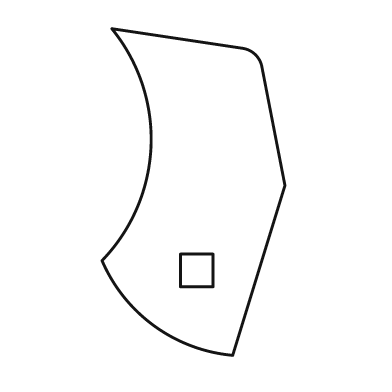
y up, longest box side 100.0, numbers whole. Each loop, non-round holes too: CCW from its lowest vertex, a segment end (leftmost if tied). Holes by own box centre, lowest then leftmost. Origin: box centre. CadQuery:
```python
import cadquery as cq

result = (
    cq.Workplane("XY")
    .moveTo(12.0, -50.0)
    .lineTo(28.0, 2.0)
    .lineTo(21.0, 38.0)
    .threePointArc((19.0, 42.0), (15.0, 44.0))
    .lineTo(-25.0, 50.0)
    .threePointArc((-13.0, 14.0), (-28.0, -21.0))
    .threePointArc((-12.0, -41.0), (12.0, -50.0))
    .close()
    .moveTo(-4.0, -29.0)
    .lineTo(6.0, -29.0)
    .lineTo(6.0, -19.0)
    .lineTo(-4.0, -19.0)
    .close()
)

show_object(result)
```